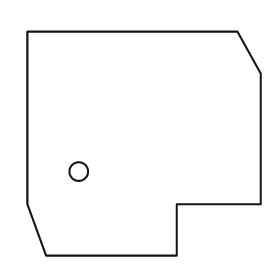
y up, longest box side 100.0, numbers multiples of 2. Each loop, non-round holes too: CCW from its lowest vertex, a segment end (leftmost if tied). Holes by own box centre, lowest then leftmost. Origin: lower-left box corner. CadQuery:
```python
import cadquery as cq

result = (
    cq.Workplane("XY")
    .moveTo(8.0, 0.0)
    .lineTo(64.0, 0.0)
    .lineTo(64.0, 22.0)
    .lineTo(100.0, 22.0)
    .lineTo(100.0, 78.0)
    .lineTo(90.0, 96.0)
    .lineTo(0.0, 96.0)
    .lineTo(0.0, 22.0)
    .close()
    .moveTo(22.0, 36.0)
    .circle(4.0)
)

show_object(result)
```